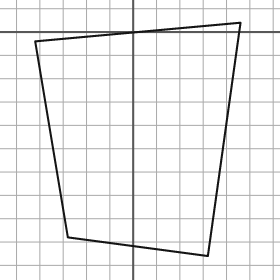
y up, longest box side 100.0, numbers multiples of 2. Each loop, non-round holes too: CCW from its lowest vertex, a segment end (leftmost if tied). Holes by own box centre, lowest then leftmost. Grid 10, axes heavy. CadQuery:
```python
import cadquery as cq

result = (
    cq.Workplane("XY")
    .moveTo(32.0, -96.0)
    .lineTo(46.0, 4.0)
    .lineTo(-42.0, -4.0)
    .lineTo(-28.0, -88.0)
    .close()
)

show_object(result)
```